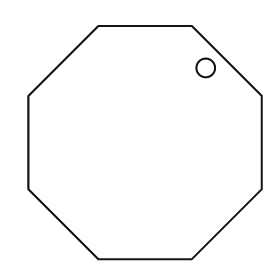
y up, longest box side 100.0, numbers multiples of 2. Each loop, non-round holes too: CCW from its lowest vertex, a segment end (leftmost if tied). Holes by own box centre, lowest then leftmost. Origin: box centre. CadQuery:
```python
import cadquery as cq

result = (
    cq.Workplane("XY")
    .moveTo(-20.0, -50.0)
    .lineTo(20.0, -50.0)
    .lineTo(50.0, -20.0)
    .lineTo(50.0, 20.0)
    .lineTo(20.0, 50.0)
    .lineTo(-20.0, 50.0)
    .lineTo(-50.0, 20.0)
    .lineTo(-50.0, -20.0)
    .close()
    .moveTo(26.0, 32.0)
    .circle(4.0)
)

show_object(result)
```